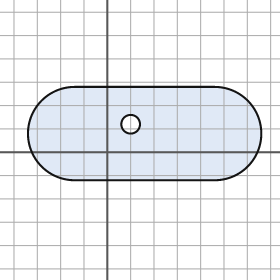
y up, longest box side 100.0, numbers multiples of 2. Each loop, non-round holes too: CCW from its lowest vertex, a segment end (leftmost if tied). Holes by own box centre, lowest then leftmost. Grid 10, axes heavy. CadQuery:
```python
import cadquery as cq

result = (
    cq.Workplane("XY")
    .moveTo(-14.0, -12.0)
    .lineTo(46.0, -12.0)
    .threePointArc((66.0, 8.0), (46.0, 28.0))
    .lineTo(-14.0, 28.0)
    .threePointArc((-34.0, 8.0), (-14.0, -12.0))
    .close()
    .moveTo(10.0, 12.0)
    .circle(4.0)
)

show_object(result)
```